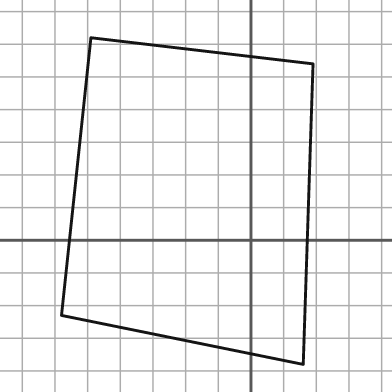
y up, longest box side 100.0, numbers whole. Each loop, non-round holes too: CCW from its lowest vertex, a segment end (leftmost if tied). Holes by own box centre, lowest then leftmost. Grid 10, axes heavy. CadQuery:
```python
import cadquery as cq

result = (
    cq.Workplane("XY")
    .moveTo(16.0, -38.0)
    .lineTo(19.0, 54.0)
    .lineTo(-49.0, 62.0)
    .lineTo(-58.0, -23.0)
    .close()
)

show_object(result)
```